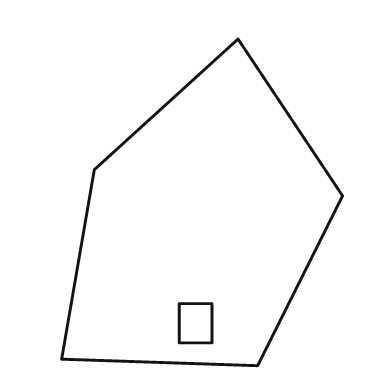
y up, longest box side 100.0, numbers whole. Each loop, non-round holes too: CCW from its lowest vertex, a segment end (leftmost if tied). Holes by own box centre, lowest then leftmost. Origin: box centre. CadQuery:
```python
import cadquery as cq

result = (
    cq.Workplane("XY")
    .moveTo(17.0, -50.0)
    .lineTo(43.0, 2.0)
    .lineTo(11.0, 50.0)
    .lineTo(-33.0, 10.0)
    .lineTo(-43.0, -48.0)
    .close()
    .moveTo(-7.0, -43.0)
    .lineTo(3.0, -43.0)
    .lineTo(3.0, -31.0)
    .lineTo(-7.0, -31.0)
    .close()
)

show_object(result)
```